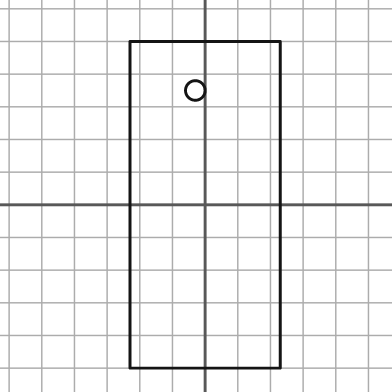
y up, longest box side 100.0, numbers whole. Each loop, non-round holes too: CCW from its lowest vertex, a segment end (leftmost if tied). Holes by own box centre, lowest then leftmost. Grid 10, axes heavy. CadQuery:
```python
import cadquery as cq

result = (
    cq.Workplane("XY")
    .moveTo(-23.0, -50.0)
    .lineTo(23.0, -50.0)
    .lineTo(23.0, 50.0)
    .lineTo(-23.0, 50.0)
    .close()
    .moveTo(-3.0, 35.0)
    .circle(3.0)
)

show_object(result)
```